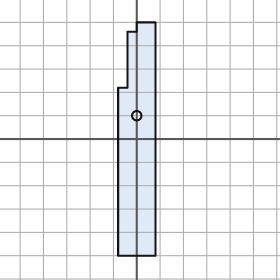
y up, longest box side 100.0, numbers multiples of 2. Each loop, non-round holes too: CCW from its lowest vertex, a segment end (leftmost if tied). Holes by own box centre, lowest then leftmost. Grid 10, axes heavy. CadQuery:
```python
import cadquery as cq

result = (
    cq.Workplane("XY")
    .moveTo(-8.0, -50.0)
    .lineTo(8.0, -50.0)
    .lineTo(8.0, 50.0)
    .lineTo(0.0, 50.0)
    .lineTo(0.0, 46.0)
    .lineTo(-4.0, 46.0)
    .lineTo(-4.0, 22.0)
    .lineTo(-8.0, 22.0)
    .close()
    .moveTo(0.0, 10.0)
    .circle(2.0)
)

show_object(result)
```